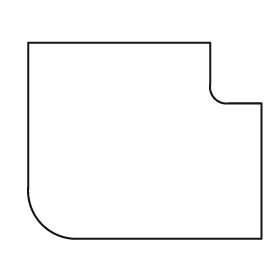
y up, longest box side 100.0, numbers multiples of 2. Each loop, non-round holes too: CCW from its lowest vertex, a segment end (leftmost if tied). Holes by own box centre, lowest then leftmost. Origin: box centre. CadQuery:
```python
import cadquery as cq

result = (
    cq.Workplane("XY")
    .moveTo(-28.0, -42.0)
    .lineTo(50.0, -42.0)
    .lineTo(50.0, 16.0)
    .lineTo(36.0, 16.0)
    .threePointArc((30.0, 18.0), (28.0, 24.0))
    .lineTo(28.0, 42.0)
    .lineTo(-50.0, 42.0)
    .lineTo(-50.0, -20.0)
    .threePointArc((-44.0, -36.0), (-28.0, -42.0))
    .close()
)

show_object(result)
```